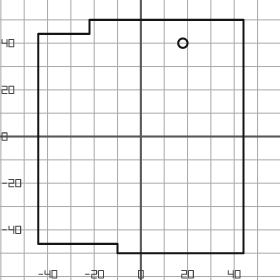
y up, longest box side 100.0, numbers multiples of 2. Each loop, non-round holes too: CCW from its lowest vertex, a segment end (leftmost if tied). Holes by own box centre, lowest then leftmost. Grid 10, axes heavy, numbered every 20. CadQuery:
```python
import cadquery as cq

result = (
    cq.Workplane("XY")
    .moveTo(-10.0, -50.0)
    .lineTo(44.0, -50.0)
    .lineTo(44.0, 50.0)
    .lineTo(-22.0, 50.0)
    .lineTo(-22.0, 44.0)
    .lineTo(-44.0, 44.0)
    .lineTo(-44.0, -46.0)
    .lineTo(-10.0, -46.0)
    .close()
    .moveTo(18.0, 40.0)
    .circle(2.0)
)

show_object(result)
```